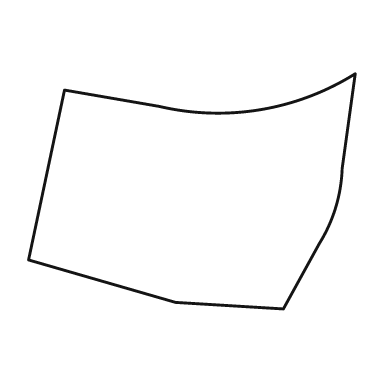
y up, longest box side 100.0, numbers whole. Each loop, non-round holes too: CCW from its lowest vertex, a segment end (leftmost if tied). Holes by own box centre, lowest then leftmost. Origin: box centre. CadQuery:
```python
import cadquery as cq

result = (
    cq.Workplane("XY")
    .moveTo(28.0, -36.0)
    .lineTo(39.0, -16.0)
    .threePointArc((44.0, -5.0), (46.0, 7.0))
    .lineTo(50.0, 36.0)
    .threePointArc((21.0, 25.0), (-10.0, 26.0))
    .lineTo(-39.0, 31.0)
    .lineTo(-50.0, -21.0)
    .lineTo(-5.0, -34.0)
    .close()
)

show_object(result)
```